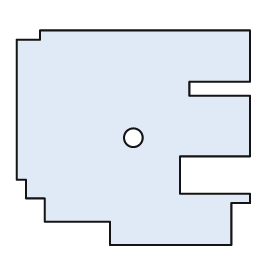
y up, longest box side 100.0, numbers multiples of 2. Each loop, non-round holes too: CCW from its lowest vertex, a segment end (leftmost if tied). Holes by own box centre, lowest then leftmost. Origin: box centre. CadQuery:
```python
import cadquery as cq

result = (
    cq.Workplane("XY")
    .moveTo(-10.0, -46.0)
    .lineTo(42.0, -46.0)
    .lineTo(42.0, -28.0)
    .lineTo(50.0, -28.0)
    .lineTo(50.0, -24.0)
    .lineTo(20.0, -24.0)
    .lineTo(20.0, -8.0)
    .lineTo(50.0, -8.0)
    .lineTo(50.0, 18.0)
    .lineTo(24.0, 18.0)
    .lineTo(24.0, 24.0)
    .lineTo(50.0, 24.0)
    .lineTo(50.0, 46.0)
    .lineTo(-40.0, 46.0)
    .lineTo(-40.0, 42.0)
    .lineTo(-50.0, 42.0)
    .lineTo(-50.0, -18.0)
    .lineTo(-46.0, -18.0)
    .lineTo(-46.0, -26.0)
    .lineTo(-38.0, -26.0)
    .lineTo(-38.0, -36.0)
    .lineTo(-10.0, -36.0)
    .close()
    .moveTo(0.0, 0.0)
    .circle(4.0)
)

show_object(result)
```